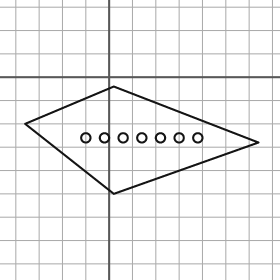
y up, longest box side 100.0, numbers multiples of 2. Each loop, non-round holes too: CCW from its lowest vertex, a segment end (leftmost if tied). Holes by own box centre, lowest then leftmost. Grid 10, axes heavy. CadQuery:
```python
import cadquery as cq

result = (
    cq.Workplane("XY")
    .moveTo(2.0, -50.0)
    .lineTo(64.0, -28.0)
    .lineTo(2.0, -4.0)
    .lineTo(-36.0, -20.0)
    .close()
    .moveTo(-10.0, -26.0)
    .circle(2.0)
    .moveTo(-2.0, -26.0)
    .circle(2.0)
    .moveTo(6.0, -26.0)
    .circle(2.0)
    .moveTo(14.0, -26.0)
    .circle(2.0)
    .moveTo(22.0, -26.0)
    .circle(2.0)
    .moveTo(30.0, -26.0)
    .circle(2.0)
    .moveTo(38.0, -26.0)
    .circle(2.0)
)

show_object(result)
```